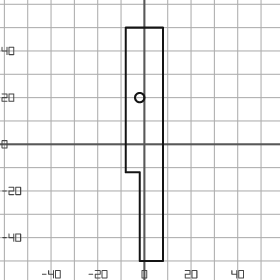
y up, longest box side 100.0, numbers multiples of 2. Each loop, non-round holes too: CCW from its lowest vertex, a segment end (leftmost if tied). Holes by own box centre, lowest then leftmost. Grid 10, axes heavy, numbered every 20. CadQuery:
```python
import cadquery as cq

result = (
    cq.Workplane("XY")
    .moveTo(-2.0, -50.0)
    .lineTo(8.0, -50.0)
    .lineTo(8.0, 50.0)
    .lineTo(-8.0, 50.0)
    .lineTo(-8.0, -12.0)
    .lineTo(-2.0, -12.0)
    .close()
    .moveTo(-2.0, 20.0)
    .circle(2.0)
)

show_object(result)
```